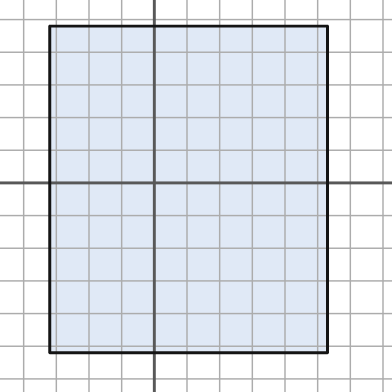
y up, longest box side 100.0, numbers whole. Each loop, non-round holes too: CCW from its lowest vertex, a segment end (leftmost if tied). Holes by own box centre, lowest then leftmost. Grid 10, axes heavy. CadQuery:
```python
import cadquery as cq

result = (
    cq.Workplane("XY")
    .moveTo(-32.0, -52.0)
    .lineTo(53.0, -52.0)
    .lineTo(53.0, 48.0)
    .lineTo(-32.0, 48.0)
    .close()
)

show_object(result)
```